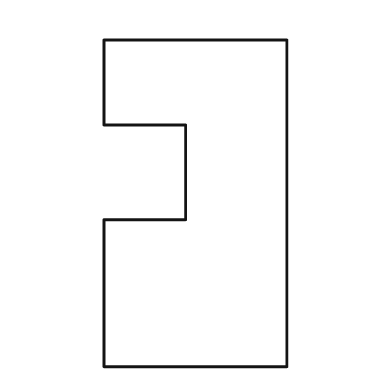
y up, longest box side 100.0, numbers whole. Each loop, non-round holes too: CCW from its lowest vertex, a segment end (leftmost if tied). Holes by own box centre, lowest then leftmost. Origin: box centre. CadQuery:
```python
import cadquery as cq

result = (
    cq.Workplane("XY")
    .moveTo(-28.0, -50.0)
    .lineTo(28.0, -50.0)
    .lineTo(28.0, 50.0)
    .lineTo(-28.0, 50.0)
    .lineTo(-28.0, 24.0)
    .lineTo(-3.0, 24.0)
    .lineTo(-3.0, -5.0)
    .lineTo(-28.0, -5.0)
    .close()
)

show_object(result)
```